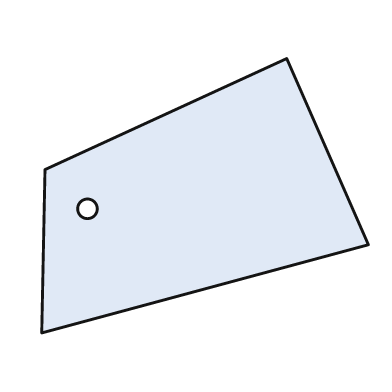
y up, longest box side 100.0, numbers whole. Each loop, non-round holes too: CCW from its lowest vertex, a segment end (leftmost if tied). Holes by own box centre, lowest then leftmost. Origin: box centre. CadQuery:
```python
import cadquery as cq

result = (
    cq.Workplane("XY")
    .moveTo(-50.0, -42.0)
    .lineTo(50.0, -15.0)
    .lineTo(25.0, 42.0)
    .lineTo(-49.0, 8.0)
    .close()
    .moveTo(-36.0, -4.0)
    .circle(3.0)
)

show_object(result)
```